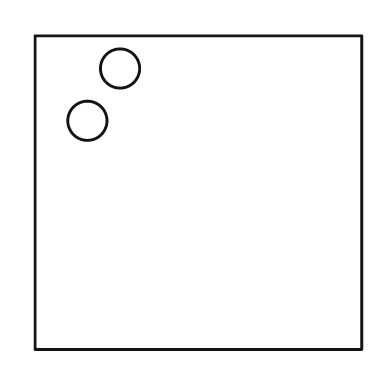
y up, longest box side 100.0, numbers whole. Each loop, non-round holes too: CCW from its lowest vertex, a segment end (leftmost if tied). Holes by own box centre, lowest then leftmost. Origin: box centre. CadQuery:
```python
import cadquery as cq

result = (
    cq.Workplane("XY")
    .moveTo(-50.0, -48.0)
    .lineTo(50.0, -48.0)
    .lineTo(50.0, 48.0)
    .lineTo(-50.0, 48.0)
    .close()
    .moveTo(-34.0, 22.0)
    .circle(6.0)
    .moveTo(-24.0, 38.0)
    .circle(6.0)
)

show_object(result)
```